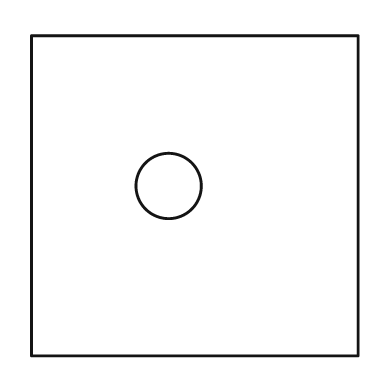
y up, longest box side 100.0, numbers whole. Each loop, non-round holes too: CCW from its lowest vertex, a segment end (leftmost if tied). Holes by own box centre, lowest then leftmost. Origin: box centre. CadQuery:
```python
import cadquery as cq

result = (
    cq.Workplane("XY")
    .moveTo(-50.0, -49.0)
    .lineTo(50.0, -49.0)
    .lineTo(50.0, 49.0)
    .lineTo(-50.0, 49.0)
    .close()
    .moveTo(-8.0, 3.0)
    .circle(10.0)
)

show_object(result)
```